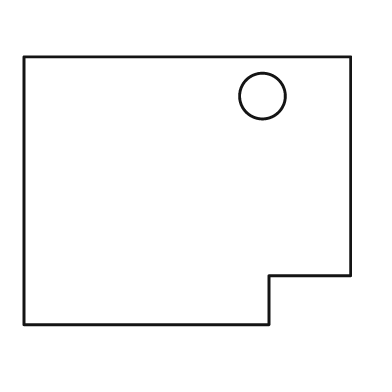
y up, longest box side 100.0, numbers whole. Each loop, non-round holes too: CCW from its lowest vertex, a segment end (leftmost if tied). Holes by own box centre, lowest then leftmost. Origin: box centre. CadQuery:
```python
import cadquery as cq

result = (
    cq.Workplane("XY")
    .moveTo(-50.0, -41.0)
    .lineTo(25.0, -41.0)
    .lineTo(25.0, -26.0)
    .lineTo(50.0, -26.0)
    .lineTo(50.0, 41.0)
    .lineTo(-50.0, 41.0)
    .close()
    .moveTo(23.0, 29.0)
    .circle(7.0)
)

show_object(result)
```